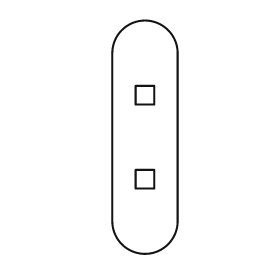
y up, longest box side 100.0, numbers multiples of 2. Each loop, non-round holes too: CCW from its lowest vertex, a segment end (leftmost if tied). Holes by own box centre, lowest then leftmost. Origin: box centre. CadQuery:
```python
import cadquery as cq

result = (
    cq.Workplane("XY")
    .moveTo(-14.0, -36.0)
    .threePointArc((0.0, -50.0), (14.0, -36.0))
    .lineTo(14.0, 36.0)
    .threePointArc((0.0, 50.0), (-14.0, 36.0))
    .close()
    .moveTo(-4.0, -22.0)
    .lineTo(4.0, -22.0)
    .lineTo(4.0, -14.0)
    .lineTo(-4.0, -14.0)
    .close()
    .moveTo(-4.0, 14.0)
    .lineTo(4.0, 14.0)
    .lineTo(4.0, 22.0)
    .lineTo(-4.0, 22.0)
    .close()
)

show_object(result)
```